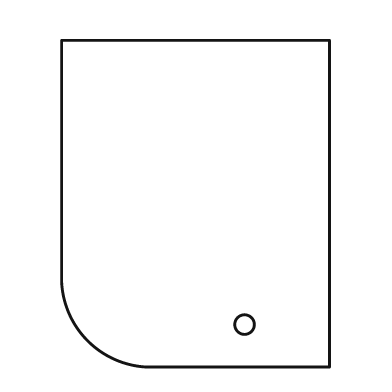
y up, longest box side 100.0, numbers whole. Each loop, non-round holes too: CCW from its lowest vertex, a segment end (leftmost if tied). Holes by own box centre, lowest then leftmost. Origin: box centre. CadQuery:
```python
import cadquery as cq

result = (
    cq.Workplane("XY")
    .moveTo(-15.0, -50.0)
    .lineTo(41.0, -50.0)
    .lineTo(41.0, 50.0)
    .lineTo(-41.0, 50.0)
    .lineTo(-41.0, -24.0)
    .threePointArc((-33.0, -42.0), (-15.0, -50.0))
    .close()
    .moveTo(15.0, -37.0)
    .circle(3.0)
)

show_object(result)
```